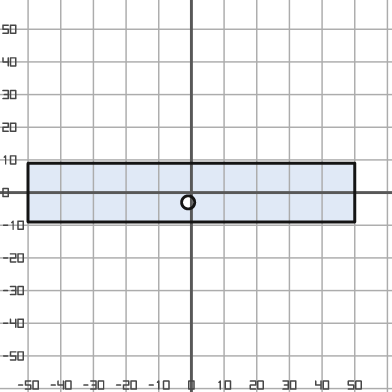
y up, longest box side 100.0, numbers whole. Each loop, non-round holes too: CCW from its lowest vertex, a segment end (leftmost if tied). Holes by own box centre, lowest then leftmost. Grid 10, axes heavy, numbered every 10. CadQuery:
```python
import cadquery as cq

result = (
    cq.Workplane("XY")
    .moveTo(-50.0, -9.0)
    .lineTo(50.0, -9.0)
    .lineTo(50.0, 9.0)
    .lineTo(-50.0, 9.0)
    .close()
    .moveTo(-1.0, -3.0)
    .circle(2.0)
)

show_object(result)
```